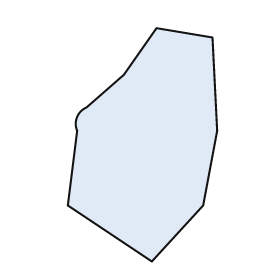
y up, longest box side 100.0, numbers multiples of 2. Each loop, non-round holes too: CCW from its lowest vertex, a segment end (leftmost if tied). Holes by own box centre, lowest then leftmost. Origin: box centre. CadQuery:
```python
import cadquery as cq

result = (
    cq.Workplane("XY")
    .moveTo(4.0, -50.0)
    .lineTo(26.0, -26.0)
    .lineTo(32.0, 6.0)
    .lineTo(30.0, 46.0)
    .lineTo(6.0, 50.0)
    .lineTo(-8.0, 30.0)
    .lineTo(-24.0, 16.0)
    .threePointArc((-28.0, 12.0), (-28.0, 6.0))
    .lineTo(-32.0, -26.0)
    .close()
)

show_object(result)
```